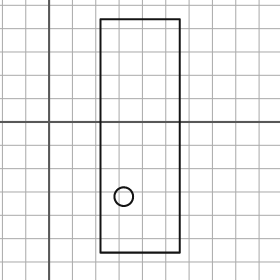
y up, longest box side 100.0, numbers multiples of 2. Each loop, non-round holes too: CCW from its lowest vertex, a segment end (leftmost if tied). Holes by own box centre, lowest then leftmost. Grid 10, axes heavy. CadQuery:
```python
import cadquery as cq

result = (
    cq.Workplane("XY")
    .moveTo(22.0, -56.0)
    .lineTo(56.0, -56.0)
    .lineTo(56.0, 44.0)
    .lineTo(22.0, 44.0)
    .close()
    .moveTo(32.0, -32.0)
    .circle(4.0)
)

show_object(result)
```